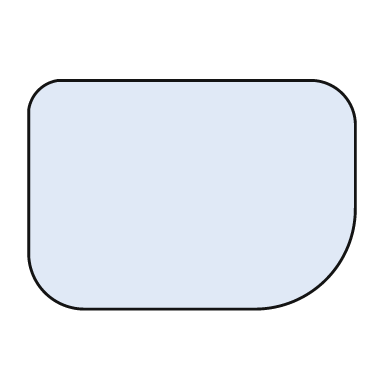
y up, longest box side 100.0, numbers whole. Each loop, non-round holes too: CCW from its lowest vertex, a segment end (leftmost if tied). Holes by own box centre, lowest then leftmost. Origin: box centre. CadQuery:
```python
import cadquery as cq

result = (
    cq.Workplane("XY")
    .moveTo(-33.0, -35.0)
    .lineTo(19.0, -35.0)
    .threePointArc((41.0, -26.0), (50.0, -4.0))
    .lineTo(50.0, 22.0)
    .threePointArc((46.0, 31.0), (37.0, 35.0))
    .lineTo(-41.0, 35.0)
    .threePointArc((-47.0, 32.0), (-50.0, 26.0))
    .lineTo(-50.0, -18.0)
    .threePointArc((-45.0, -30.0), (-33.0, -35.0))
    .close()
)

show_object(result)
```